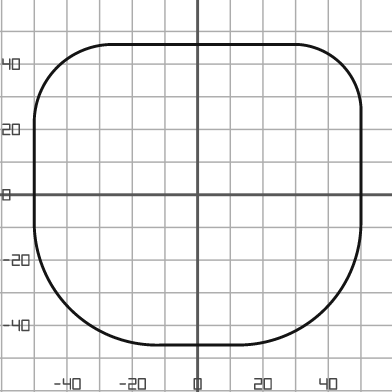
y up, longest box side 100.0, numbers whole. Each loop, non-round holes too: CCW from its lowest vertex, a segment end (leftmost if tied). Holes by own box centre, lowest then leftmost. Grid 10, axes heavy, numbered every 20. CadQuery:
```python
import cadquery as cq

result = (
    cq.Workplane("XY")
    .moveTo(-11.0, -46.0)
    .lineTo(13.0, -46.0)
    .threePointArc((39.0, -35.0), (50.0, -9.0))
    .lineTo(50.0, 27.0)
    .threePointArc((44.0, 40.0), (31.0, 46.0))
    .lineTo(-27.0, 46.0)
    .threePointArc((-43.0, 39.0), (-50.0, 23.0))
    .lineTo(-50.0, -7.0)
    .threePointArc((-39.0, -35.0), (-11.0, -46.0))
    .close()
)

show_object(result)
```